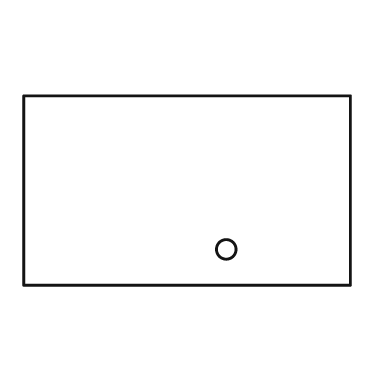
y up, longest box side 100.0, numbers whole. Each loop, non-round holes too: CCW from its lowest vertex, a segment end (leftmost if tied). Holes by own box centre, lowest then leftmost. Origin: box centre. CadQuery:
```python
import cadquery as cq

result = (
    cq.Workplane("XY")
    .moveTo(-50.0, -29.0)
    .lineTo(50.0, -29.0)
    .lineTo(50.0, 29.0)
    .lineTo(-50.0, 29.0)
    .close()
    .moveTo(12.0, -18.0)
    .circle(3.0)
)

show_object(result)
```